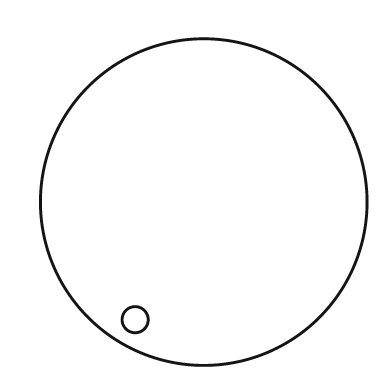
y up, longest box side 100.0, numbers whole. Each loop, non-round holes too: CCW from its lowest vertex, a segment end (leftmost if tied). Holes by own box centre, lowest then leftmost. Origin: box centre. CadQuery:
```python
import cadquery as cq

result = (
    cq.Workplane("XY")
    .moveTo(0.0, 0.0)
    .circle(50.0)
    .moveTo(-21.0, -36.0)
    .circle(4.0)
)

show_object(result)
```